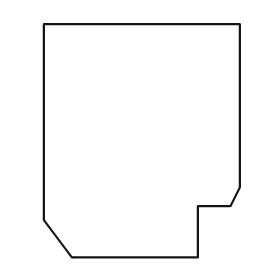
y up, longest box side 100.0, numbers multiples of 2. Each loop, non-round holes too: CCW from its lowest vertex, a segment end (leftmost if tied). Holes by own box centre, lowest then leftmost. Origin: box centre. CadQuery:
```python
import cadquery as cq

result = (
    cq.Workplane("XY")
    .moveTo(-30.0, -50.0)
    .lineTo(24.0, -50.0)
    .lineTo(24.0, -28.0)
    .lineTo(38.0, -28.0)
    .lineTo(42.0, -20.0)
    .lineTo(42.0, 50.0)
    .lineTo(-42.0, 50.0)
    .lineTo(-42.0, -34.0)
    .close()
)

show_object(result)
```